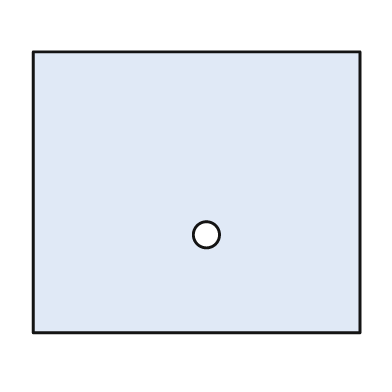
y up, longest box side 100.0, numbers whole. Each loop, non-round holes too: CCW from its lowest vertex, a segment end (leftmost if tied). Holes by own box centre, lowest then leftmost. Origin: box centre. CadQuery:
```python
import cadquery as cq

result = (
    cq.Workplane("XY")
    .moveTo(-50.0, -43.0)
    .lineTo(50.0, -43.0)
    .lineTo(50.0, 43.0)
    .lineTo(-50.0, 43.0)
    .close()
    .moveTo(3.0, -13.0)
    .circle(4.0)
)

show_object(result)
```